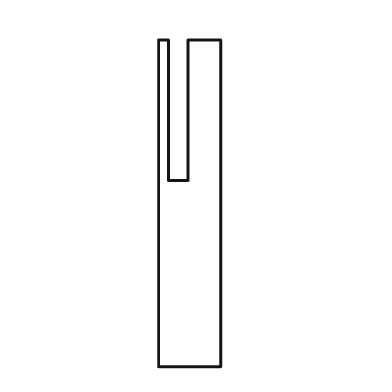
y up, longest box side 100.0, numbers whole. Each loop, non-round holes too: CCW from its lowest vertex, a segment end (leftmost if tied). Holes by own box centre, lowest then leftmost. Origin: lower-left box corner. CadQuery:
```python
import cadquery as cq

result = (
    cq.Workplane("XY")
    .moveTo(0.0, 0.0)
    .lineTo(19.0, 0.0)
    .lineTo(19.0, 100.0)
    .lineTo(9.0, 100.0)
    .lineTo(9.0, 57.0)
    .lineTo(3.0, 57.0)
    .lineTo(3.0, 100.0)
    .lineTo(0.0, 100.0)
    .close()
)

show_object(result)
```